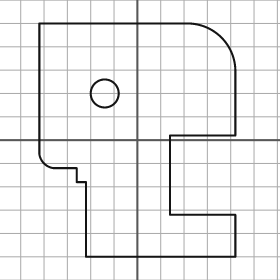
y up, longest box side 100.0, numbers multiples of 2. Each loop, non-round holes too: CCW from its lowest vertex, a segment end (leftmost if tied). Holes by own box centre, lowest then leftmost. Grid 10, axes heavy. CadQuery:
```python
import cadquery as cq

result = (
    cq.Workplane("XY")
    .moveTo(-22.0, -50.0)
    .lineTo(42.0, -50.0)
    .lineTo(42.0, -32.0)
    .lineTo(14.0, -32.0)
    .lineTo(14.0, 2.0)
    .lineTo(42.0, 2.0)
    .lineTo(42.0, 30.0)
    .threePointArc((36.0, 44.0), (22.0, 50.0))
    .lineTo(-42.0, 50.0)
    .lineTo(-42.0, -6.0)
    .threePointArc((-40.0, -10.0), (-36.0, -12.0))
    .lineTo(-26.0, -12.0)
    .lineTo(-26.0, -18.0)
    .lineTo(-22.0, -18.0)
    .close()
    .moveTo(-14.0, 20.0)
    .circle(6.0)
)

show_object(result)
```